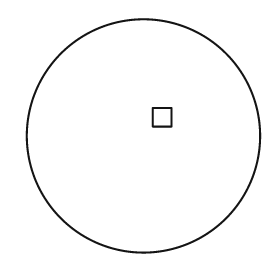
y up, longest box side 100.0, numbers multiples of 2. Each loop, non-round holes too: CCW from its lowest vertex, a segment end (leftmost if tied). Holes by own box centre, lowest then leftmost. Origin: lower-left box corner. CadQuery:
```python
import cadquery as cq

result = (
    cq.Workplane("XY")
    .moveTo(50.0, 50.0)
    .circle(50.0)
    .moveTo(54.0, 54.0)
    .lineTo(62.0, 54.0)
    .lineTo(62.0, 62.0)
    .lineTo(54.0, 62.0)
    .close()
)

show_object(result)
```